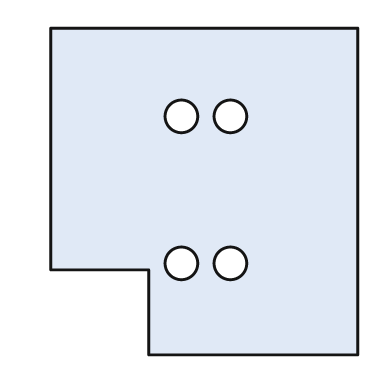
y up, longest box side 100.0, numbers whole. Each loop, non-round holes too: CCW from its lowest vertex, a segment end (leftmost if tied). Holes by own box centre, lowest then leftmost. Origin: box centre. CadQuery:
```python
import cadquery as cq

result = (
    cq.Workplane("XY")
    .moveTo(-17.0, -50.0)
    .lineTo(47.0, -50.0)
    .lineTo(47.0, 50.0)
    .lineTo(-47.0, 50.0)
    .lineTo(-47.0, -24.0)
    .lineTo(-17.0, -24.0)
    .close()
    .moveTo(-7.0, -22.0)
    .circle(5.0)
    .moveTo(8.0, -22.0)
    .circle(5.0)
    .moveTo(-7.0, 23.0)
    .circle(5.0)
    .moveTo(8.0, 23.0)
    .circle(5.0)
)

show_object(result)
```